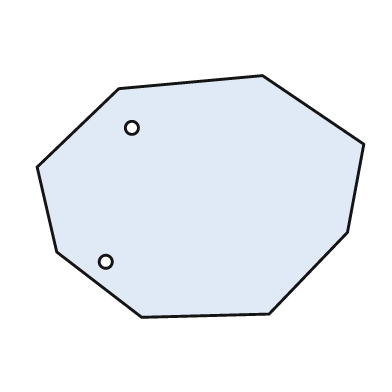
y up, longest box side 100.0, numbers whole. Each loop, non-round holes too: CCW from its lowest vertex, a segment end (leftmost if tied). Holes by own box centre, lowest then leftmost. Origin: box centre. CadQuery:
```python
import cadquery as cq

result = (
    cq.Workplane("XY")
    .moveTo(-18.0, -37.0)
    .lineTo(21.0, -36.0)
    .lineTo(45.0, -11.0)
    .lineTo(50.0, 16.0)
    .lineTo(19.0, 37.0)
    .lineTo(-25.0, 33.0)
    .lineTo(-50.0, 9.0)
    .lineTo(-44.0, -17.0)
    .close()
    .moveTo(-29.0, -20.0)
    .circle(2.0)
    .moveTo(-21.0, 21.0)
    .circle(2.0)
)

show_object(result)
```